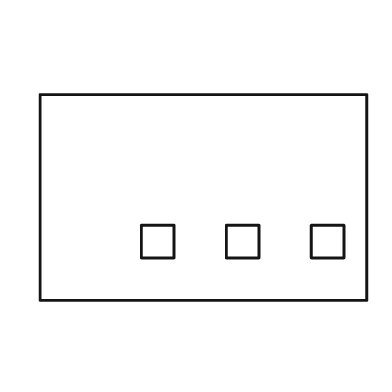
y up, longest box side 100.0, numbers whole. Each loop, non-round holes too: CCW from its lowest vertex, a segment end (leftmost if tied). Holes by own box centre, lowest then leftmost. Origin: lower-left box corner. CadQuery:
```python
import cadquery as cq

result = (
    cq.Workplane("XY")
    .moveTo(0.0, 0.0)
    .lineTo(100.0, 0.0)
    .lineTo(100.0, 63.0)
    .lineTo(0.0, 63.0)
    .close()
    .moveTo(31.0, 13.0)
    .lineTo(41.0, 13.0)
    .lineTo(41.0, 23.0)
    .lineTo(31.0, 23.0)
    .close()
    .moveTo(57.0, 13.0)
    .lineTo(67.0, 13.0)
    .lineTo(67.0, 23.0)
    .lineTo(57.0, 23.0)
    .close()
    .moveTo(83.0, 13.0)
    .lineTo(93.0, 13.0)
    .lineTo(93.0, 23.0)
    .lineTo(83.0, 23.0)
    .close()
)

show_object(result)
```